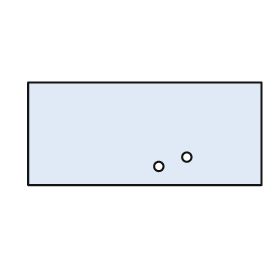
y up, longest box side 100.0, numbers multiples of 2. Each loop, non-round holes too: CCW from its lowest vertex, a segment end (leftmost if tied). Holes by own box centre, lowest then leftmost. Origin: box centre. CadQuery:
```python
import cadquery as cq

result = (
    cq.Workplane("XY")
    .moveTo(-50.0, -22.0)
    .lineTo(50.0, -22.0)
    .lineTo(50.0, 22.0)
    .lineTo(-50.0, 22.0)
    .close()
    .moveTo(6.0, -14.0)
    .circle(2.0)
    .moveTo(18.0, -10.0)
    .circle(2.0)
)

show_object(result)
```